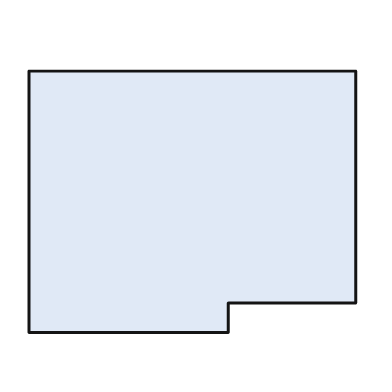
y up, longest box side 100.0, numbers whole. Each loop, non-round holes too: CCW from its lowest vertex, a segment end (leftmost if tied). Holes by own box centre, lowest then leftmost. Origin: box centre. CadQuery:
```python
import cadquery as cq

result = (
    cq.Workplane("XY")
    .moveTo(-50.0, -40.0)
    .lineTo(11.0, -40.0)
    .lineTo(11.0, -31.0)
    .lineTo(50.0, -31.0)
    .lineTo(50.0, 40.0)
    .lineTo(-50.0, 40.0)
    .close()
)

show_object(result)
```